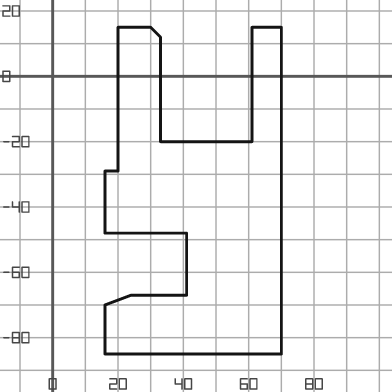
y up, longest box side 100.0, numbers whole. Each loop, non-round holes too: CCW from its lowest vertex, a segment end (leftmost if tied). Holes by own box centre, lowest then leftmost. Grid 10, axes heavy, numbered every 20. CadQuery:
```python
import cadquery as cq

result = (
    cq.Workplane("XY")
    .moveTo(16.0, -85.0)
    .lineTo(70.0, -85.0)
    .lineTo(70.0, 15.0)
    .lineTo(61.0, 15.0)
    .lineTo(61.0, -20.0)
    .lineTo(33.0, -20.0)
    .lineTo(33.0, 12.0)
    .lineTo(30.0, 15.0)
    .lineTo(20.0, 15.0)
    .lineTo(20.0, -29.0)
    .lineTo(16.0, -29.0)
    .lineTo(16.0, -48.0)
    .lineTo(41.0, -48.0)
    .lineTo(41.0, -67.0)
    .lineTo(24.0, -67.0)
    .lineTo(16.0, -70.0)
    .close()
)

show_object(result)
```